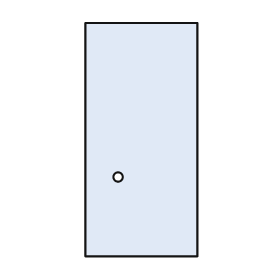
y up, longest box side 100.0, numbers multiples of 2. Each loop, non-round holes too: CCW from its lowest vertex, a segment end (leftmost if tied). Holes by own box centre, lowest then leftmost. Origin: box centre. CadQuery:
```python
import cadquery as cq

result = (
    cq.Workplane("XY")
    .moveTo(-24.0, -50.0)
    .lineTo(24.0, -50.0)
    .lineTo(24.0, 50.0)
    .lineTo(-24.0, 50.0)
    .close()
    .moveTo(-10.0, -16.0)
    .circle(2.0)
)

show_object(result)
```